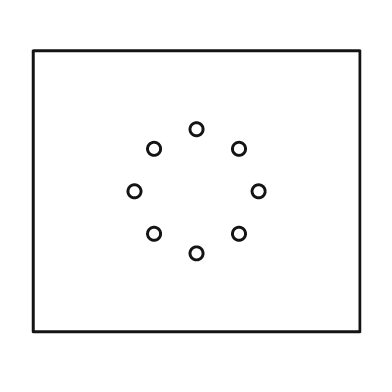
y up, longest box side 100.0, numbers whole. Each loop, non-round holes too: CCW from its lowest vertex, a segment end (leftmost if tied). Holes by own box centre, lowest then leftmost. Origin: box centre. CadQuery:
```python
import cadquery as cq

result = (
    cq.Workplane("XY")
    .moveTo(-50.0, -43.0)
    .lineTo(50.0, -43.0)
    .lineTo(50.0, 43.0)
    .lineTo(-50.0, 43.0)
    .close()
    .moveTo(0.0, -19.0)
    .circle(2.0)
    .moveTo(-13.0, -13.0)
    .circle(2.0)
    .moveTo(13.0, -13.0)
    .circle(2.0)
    .moveTo(-19.0, 0.0)
    .circle(2.0)
    .moveTo(19.0, 0.0)
    .circle(2.0)
    .moveTo(-13.0, 13.0)
    .circle(2.0)
    .moveTo(13.0, 13.0)
    .circle(2.0)
    .moveTo(0.0, 19.0)
    .circle(2.0)
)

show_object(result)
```